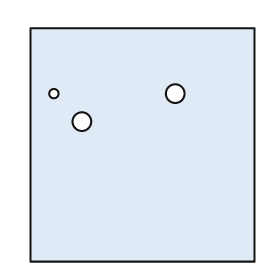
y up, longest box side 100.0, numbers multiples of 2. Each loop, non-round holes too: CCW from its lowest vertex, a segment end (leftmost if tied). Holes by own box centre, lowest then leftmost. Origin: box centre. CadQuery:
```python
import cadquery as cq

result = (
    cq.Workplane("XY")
    .moveTo(-48.0, -50.0)
    .lineTo(48.0, -50.0)
    .lineTo(48.0, 50.0)
    .lineTo(-48.0, 50.0)
    .close()
    .moveTo(-26.0, 10.0)
    .circle(4.0)
    .moveTo(-38.0, 22.0)
    .circle(2.0)
    .moveTo(14.0, 22.0)
    .circle(4.0)
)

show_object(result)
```